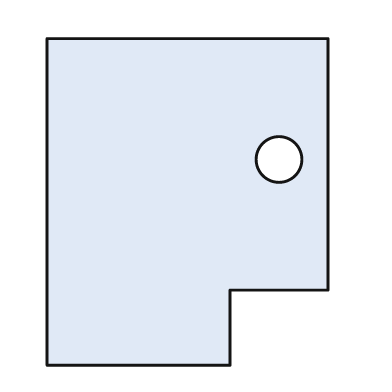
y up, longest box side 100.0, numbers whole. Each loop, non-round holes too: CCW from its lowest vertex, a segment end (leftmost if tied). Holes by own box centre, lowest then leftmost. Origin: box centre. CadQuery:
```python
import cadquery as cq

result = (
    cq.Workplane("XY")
    .moveTo(-43.0, -50.0)
    .lineTo(13.0, -50.0)
    .lineTo(13.0, -27.0)
    .lineTo(43.0, -27.0)
    .lineTo(43.0, 50.0)
    .lineTo(-43.0, 50.0)
    .close()
    .moveTo(28.0, 13.0)
    .circle(7.0)
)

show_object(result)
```